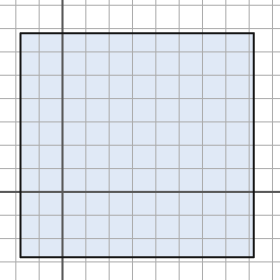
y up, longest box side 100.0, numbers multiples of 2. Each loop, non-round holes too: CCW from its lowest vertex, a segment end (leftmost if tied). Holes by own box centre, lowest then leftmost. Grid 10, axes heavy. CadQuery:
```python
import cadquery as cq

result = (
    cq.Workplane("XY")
    .moveTo(-18.0, -28.0)
    .lineTo(82.0, -28.0)
    .lineTo(82.0, 68.0)
    .lineTo(-18.0, 68.0)
    .close()
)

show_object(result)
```